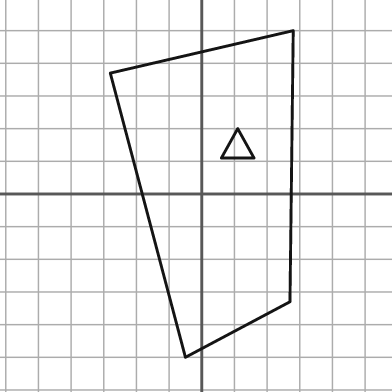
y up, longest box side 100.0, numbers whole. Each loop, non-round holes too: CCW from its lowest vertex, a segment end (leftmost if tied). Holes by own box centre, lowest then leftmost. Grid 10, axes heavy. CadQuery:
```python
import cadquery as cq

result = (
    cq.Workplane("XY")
    .moveTo(-5.0, -50.0)
    .lineTo(27.0, -33.0)
    .lineTo(28.0, 50.0)
    .lineTo(-28.0, 37.0)
    .close()
    .moveTo(6.0, 11.0)
    .lineTo(16.0, 11.0)
    .lineTo(11.0, 20.0)
    .close()
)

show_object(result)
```